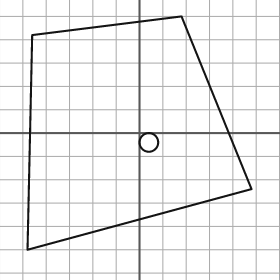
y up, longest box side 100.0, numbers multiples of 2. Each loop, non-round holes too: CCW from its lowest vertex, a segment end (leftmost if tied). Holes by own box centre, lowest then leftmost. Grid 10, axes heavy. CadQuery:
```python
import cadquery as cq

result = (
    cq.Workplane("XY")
    .moveTo(-48.0, -50.0)
    .lineTo(48.0, -24.0)
    .lineTo(18.0, 50.0)
    .lineTo(-46.0, 42.0)
    .close()
    .moveTo(4.0, -4.0)
    .circle(4.0)
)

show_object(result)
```